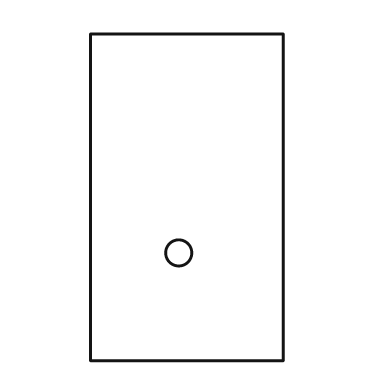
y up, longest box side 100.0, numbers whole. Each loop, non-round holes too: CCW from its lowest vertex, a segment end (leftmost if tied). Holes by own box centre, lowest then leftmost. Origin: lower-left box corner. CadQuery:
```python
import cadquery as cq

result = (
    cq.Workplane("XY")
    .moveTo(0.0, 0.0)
    .lineTo(59.0, 0.0)
    .lineTo(59.0, 100.0)
    .lineTo(0.0, 100.0)
    .close()
    .moveTo(27.0, 33.0)
    .circle(4.0)
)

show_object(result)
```